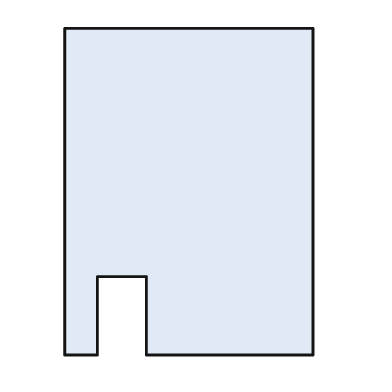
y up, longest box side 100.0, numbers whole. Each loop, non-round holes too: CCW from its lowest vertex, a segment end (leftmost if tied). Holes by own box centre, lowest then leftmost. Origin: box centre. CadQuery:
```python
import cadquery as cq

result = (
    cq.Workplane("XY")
    .moveTo(-38.0, -50.0)
    .lineTo(-28.0, -50.0)
    .lineTo(-28.0, -26.0)
    .lineTo(-13.0, -26.0)
    .lineTo(-13.0, -50.0)
    .lineTo(38.0, -50.0)
    .lineTo(38.0, 50.0)
    .lineTo(-38.0, 50.0)
    .close()
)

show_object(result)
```